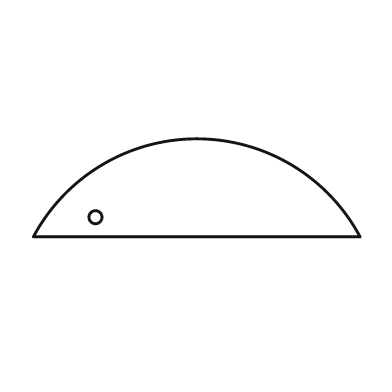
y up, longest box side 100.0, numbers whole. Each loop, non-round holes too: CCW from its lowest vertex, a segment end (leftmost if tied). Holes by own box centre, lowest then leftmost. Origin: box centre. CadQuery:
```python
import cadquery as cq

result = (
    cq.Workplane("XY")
    .moveTo(-50.0, -15.0)
    .lineTo(50.0, -15.0)
    .threePointArc((0.0, 15.0), (-50.0, -15.0))
    .close()
    .moveTo(-31.0, -9.0)
    .circle(2.0)
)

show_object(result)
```